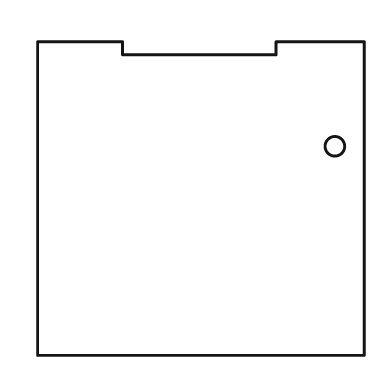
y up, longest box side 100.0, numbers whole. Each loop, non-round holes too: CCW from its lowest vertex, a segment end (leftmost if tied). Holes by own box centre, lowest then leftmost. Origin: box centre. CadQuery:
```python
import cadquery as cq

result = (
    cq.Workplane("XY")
    .moveTo(-50.0, -48.0)
    .lineTo(50.0, -48.0)
    .lineTo(50.0, 48.0)
    .lineTo(23.0, 48.0)
    .lineTo(23.0, 44.0)
    .lineTo(-24.0, 44.0)
    .lineTo(-24.0, 48.0)
    .lineTo(-50.0, 48.0)
    .close()
    .moveTo(41.0, 16.0)
    .circle(3.0)
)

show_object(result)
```